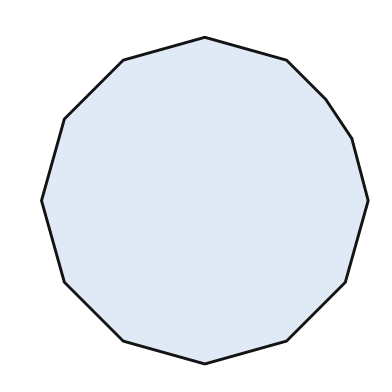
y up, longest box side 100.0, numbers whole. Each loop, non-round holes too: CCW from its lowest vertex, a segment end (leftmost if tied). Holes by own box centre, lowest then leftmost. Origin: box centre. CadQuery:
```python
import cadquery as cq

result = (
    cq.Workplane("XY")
    .moveTo(0.0, -50.0)
    .lineTo(25.0, -43.0)
    .lineTo(43.0, -25.0)
    .lineTo(50.0, 0.0)
    .lineTo(45.0, 19.0)
    .lineTo(37.0, 31.0)
    .lineTo(25.0, 43.0)
    .lineTo(0.0, 50.0)
    .lineTo(-25.0, 43.0)
    .lineTo(-43.0, 25.0)
    .lineTo(-50.0, 0.0)
    .lineTo(-43.0, -25.0)
    .lineTo(-25.0, -43.0)
    .close()
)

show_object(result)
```